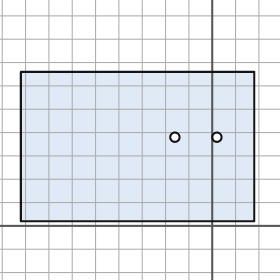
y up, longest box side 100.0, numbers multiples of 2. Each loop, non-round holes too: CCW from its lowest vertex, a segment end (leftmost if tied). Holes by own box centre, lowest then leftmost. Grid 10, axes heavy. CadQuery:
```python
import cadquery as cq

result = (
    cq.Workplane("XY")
    .moveTo(-82.0, 2.0)
    .lineTo(18.0, 2.0)
    .lineTo(18.0, 66.0)
    .lineTo(-82.0, 66.0)
    .close()
    .moveTo(-16.0, 38.0)
    .circle(2.0)
    .moveTo(2.0, 38.0)
    .circle(2.0)
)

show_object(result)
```